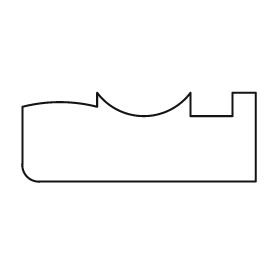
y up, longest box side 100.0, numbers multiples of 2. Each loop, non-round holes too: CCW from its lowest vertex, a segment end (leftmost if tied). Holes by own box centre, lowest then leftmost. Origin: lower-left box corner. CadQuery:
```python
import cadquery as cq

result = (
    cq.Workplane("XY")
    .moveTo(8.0, 0.0)
    .lineTo(100.0, 0.0)
    .lineTo(100.0, 38.0)
    .lineTo(90.0, 38.0)
    .lineTo(90.0, 28.0)
    .lineTo(72.0, 28.0)
    .lineTo(72.0, 38.0)
    .threePointArc((52.0, 28.0), (32.0, 38.0))
    .lineTo(32.0, 32.0)
    .threePointArc((16.0, 34.0), (0.0, 32.0))
    .lineTo(0.0, 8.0)
    .threePointArc((2.0, 2.0), (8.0, 0.0))
    .close()
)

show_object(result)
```